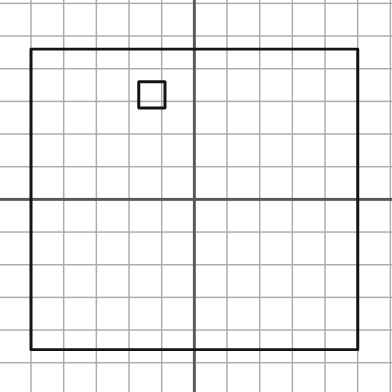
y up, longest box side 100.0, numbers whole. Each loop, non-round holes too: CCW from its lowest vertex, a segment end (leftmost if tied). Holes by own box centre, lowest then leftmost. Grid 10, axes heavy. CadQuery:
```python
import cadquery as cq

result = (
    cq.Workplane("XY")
    .moveTo(-50.0, -46.0)
    .lineTo(50.0, -46.0)
    .lineTo(50.0, 46.0)
    .lineTo(-50.0, 46.0)
    .close()
    .moveTo(-17.0, 28.0)
    .lineTo(-9.0, 28.0)
    .lineTo(-9.0, 36.0)
    .lineTo(-17.0, 36.0)
    .close()
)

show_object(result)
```